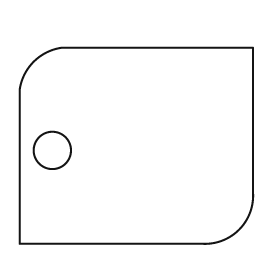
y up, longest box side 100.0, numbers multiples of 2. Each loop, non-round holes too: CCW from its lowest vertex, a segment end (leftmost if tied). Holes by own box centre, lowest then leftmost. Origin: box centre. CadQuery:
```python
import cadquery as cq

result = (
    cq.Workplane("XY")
    .moveTo(-50.0, -42.0)
    .lineTo(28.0, -42.0)
    .threePointArc((44.0, -36.0), (50.0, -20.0))
    .lineTo(50.0, 42.0)
    .lineTo(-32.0, 42.0)
    .threePointArc((-44.0, 36.0), (-50.0, 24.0))
    .close()
    .moveTo(-36.0, -2.0)
    .circle(8.0)
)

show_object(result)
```